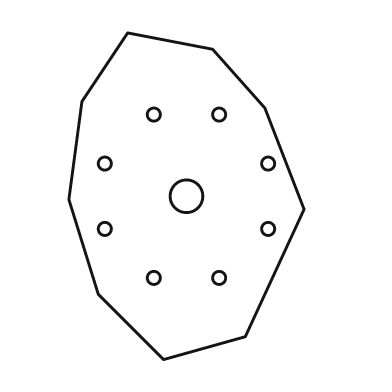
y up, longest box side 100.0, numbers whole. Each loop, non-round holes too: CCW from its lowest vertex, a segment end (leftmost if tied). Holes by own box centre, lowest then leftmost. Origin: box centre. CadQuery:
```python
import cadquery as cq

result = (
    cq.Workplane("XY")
    .moveTo(-7.0, -50.0)
    .lineTo(18.0, -43.0)
    .lineTo(36.0, -4.0)
    .lineTo(24.0, 27.0)
    .lineTo(8.0, 45.0)
    .lineTo(-18.0, 50.0)
    .lineTo(-32.0, 29.0)
    .lineTo(-36.0, -1.0)
    .lineTo(-27.0, -30.0)
    .close()
    .moveTo(-10.0, -25.0)
    .circle(2.0)
    .moveTo(10.0, -25.0)
    .circle(2.0)
    .moveTo(-25.0, -10.0)
    .circle(2.0)
    .moveTo(25.0, -10.0)
    .circle(2.0)
    .moveTo(0.0, 0.0)
    .circle(5.0)
    .moveTo(-25.0, 10.0)
    .circle(2.0)
    .moveTo(25.0, 10.0)
    .circle(2.0)
    .moveTo(-10.0, 25.0)
    .circle(2.0)
    .moveTo(10.0, 25.0)
    .circle(2.0)
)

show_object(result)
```